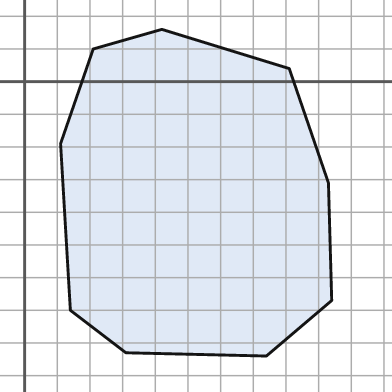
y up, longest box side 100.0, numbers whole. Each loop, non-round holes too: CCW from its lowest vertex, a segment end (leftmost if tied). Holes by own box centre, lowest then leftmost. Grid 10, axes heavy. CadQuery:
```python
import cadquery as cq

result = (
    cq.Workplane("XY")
    .moveTo(74.0, -84.0)
    .lineTo(94.0, -67.0)
    .lineTo(93.0, -31.0)
    .lineTo(81.0, 4.0)
    .lineTo(42.0, 16.0)
    .lineTo(21.0, 10.0)
    .lineTo(11.0, -19.0)
    .lineTo(14.0, -70.0)
    .lineTo(31.0, -83.0)
    .close()
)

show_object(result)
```